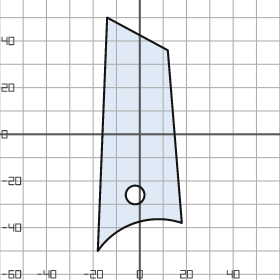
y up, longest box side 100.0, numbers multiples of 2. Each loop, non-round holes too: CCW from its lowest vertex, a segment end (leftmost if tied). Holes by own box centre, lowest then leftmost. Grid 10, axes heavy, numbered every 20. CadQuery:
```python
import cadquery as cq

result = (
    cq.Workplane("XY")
    .moveTo(-18.0, -50.0)
    .threePointArc((-2.0, -38.0), (18.0, -38.0))
    .lineTo(12.0, 36.0)
    .lineTo(-14.0, 50.0)
    .close()
    .moveTo(-2.0, -26.0)
    .circle(4.0)
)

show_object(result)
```